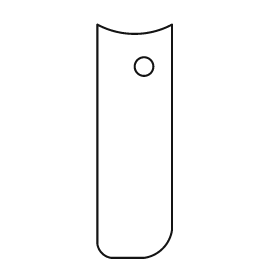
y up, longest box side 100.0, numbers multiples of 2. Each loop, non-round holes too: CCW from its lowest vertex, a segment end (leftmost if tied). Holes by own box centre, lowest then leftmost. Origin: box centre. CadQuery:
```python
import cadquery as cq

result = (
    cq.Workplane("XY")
    .moveTo(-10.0, -50.0)
    .lineTo(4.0, -50.0)
    .threePointArc((12.0, -46.0), (16.0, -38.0))
    .lineTo(16.0, 50.0)
    .threePointArc((0.0, 46.0), (-16.0, 50.0))
    .lineTo(-16.0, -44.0)
    .threePointArc((-14.0, -48.0), (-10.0, -50.0))
    .close()
    .moveTo(4.0, 32.0)
    .circle(4.0)
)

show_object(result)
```